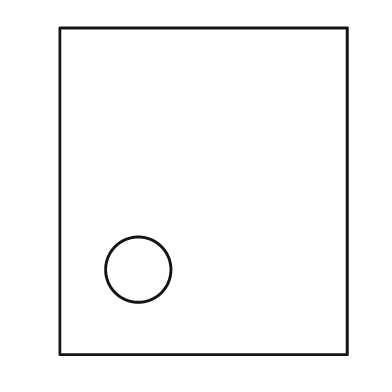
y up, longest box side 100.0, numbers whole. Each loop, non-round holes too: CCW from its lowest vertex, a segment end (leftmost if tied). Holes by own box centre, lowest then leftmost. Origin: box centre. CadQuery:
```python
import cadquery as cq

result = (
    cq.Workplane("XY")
    .moveTo(-44.0, -50.0)
    .lineTo(44.0, -50.0)
    .lineTo(44.0, 50.0)
    .lineTo(-44.0, 50.0)
    .close()
    .moveTo(-20.0, -24.0)
    .circle(10.0)
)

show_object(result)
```